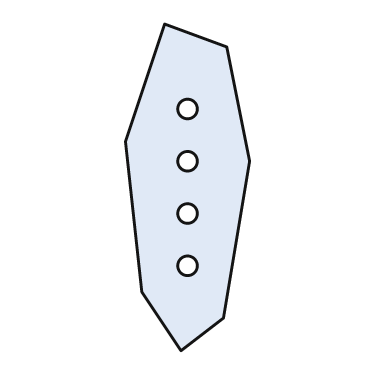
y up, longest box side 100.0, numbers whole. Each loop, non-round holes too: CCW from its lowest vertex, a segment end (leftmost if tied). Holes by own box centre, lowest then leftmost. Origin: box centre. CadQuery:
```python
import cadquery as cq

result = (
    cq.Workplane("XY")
    .moveTo(-2.0, -50.0)
    .lineTo(11.0, -40.0)
    .lineTo(19.0, 8.0)
    .lineTo(12.0, 43.0)
    .lineTo(-7.0, 50.0)
    .lineTo(-19.0, 14.0)
    .lineTo(-14.0, -32.0)
    .close()
    .moveTo(0.0, -24.0)
    .circle(3.0)
    .moveTo(0.0, -8.0)
    .circle(3.0)
    .moveTo(0.0, 8.0)
    .circle(3.0)
    .moveTo(0.0, 24.0)
    .circle(3.0)
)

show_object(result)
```